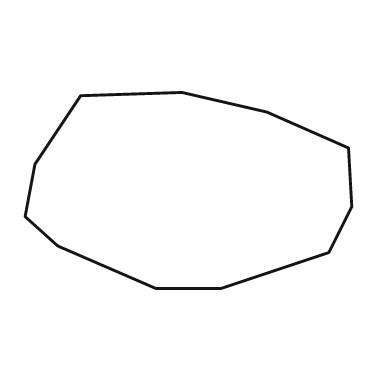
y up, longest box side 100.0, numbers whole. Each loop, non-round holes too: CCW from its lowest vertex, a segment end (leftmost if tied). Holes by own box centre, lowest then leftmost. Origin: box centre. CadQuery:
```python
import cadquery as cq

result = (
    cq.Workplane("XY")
    .moveTo(-10.0, -30.0)
    .lineTo(10.0, -30.0)
    .lineTo(43.0, -19.0)
    .lineTo(50.0, -5.0)
    .lineTo(49.0, 13.0)
    .lineTo(24.0, 24.0)
    .lineTo(-2.0, 30.0)
    .lineTo(-33.0, 29.0)
    .lineTo(-47.0, 8.0)
    .lineTo(-50.0, -8.0)
    .lineTo(-40.0, -17.0)
    .close()
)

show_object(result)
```